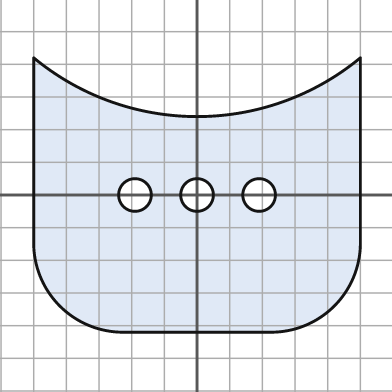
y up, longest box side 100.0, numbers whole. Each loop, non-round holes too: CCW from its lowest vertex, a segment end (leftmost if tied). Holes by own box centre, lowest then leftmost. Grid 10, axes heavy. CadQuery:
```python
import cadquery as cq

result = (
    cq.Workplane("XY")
    .moveTo(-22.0, -42.0)
    .lineTo(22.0, -42.0)
    .threePointArc((42.0, -34.0), (50.0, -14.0))
    .lineTo(50.0, 42.0)
    .threePointArc((0.0, 24.0), (-50.0, 42.0))
    .lineTo(-50.0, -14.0)
    .threePointArc((-42.0, -34.0), (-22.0, -42.0))
    .close()
    .moveTo(-19.0, 0.0)
    .circle(5.0)
    .moveTo(0.0, 0.0)
    .circle(5.0)
    .moveTo(19.0, 0.0)
    .circle(5.0)
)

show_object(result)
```